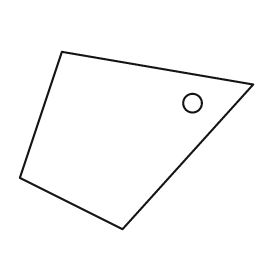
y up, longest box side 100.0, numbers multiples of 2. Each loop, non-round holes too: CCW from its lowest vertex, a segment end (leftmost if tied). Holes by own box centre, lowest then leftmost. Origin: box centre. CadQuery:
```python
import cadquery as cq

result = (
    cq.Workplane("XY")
    .moveTo(-6.0, -38.0)
    .lineTo(50.0, 24.0)
    .lineTo(-32.0, 38.0)
    .lineTo(-50.0, -16.0)
    .close()
    .moveTo(24.0, 16.0)
    .circle(4.0)
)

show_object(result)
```